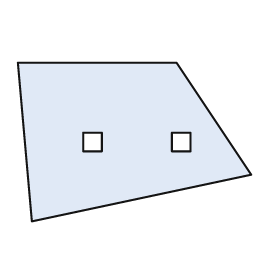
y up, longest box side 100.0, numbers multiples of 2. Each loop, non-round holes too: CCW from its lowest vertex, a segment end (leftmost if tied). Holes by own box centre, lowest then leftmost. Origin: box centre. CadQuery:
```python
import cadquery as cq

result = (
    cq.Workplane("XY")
    .moveTo(-44.0, -34.0)
    .lineTo(50.0, -14.0)
    .lineTo(18.0, 34.0)
    .lineTo(-50.0, 34.0)
    .close()
    .moveTo(-22.0, -4.0)
    .lineTo(-14.0, -4.0)
    .lineTo(-14.0, 4.0)
    .lineTo(-22.0, 4.0)
    .close()
    .moveTo(16.0, -4.0)
    .lineTo(24.0, -4.0)
    .lineTo(24.0, 4.0)
    .lineTo(16.0, 4.0)
    .close()
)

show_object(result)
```